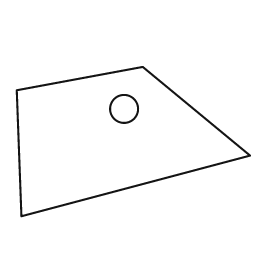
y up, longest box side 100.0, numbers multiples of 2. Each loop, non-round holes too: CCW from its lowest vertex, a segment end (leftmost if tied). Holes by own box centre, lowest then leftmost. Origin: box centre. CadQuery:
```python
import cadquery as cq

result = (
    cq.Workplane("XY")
    .moveTo(-48.0, -32.0)
    .lineTo(50.0, -6.0)
    .lineTo(4.0, 32.0)
    .lineTo(-50.0, 22.0)
    .close()
    .moveTo(-4.0, 14.0)
    .circle(6.0)
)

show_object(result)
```